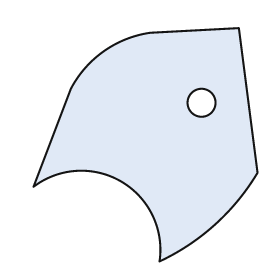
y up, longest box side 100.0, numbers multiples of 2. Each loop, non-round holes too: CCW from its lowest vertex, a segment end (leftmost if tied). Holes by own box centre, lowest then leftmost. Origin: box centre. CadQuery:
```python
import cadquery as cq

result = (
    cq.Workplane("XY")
    .moveTo(6.0, -50.0)
    .threePointArc((30.0, -34.0), (48.0, -12.0))
    .lineTo(40.0, 50.0)
    .lineTo(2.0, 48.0)
    .threePointArc((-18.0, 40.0), (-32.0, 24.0))
    .lineTo(-48.0, -18.0)
    .threePointArc((-10.0, -16.0), (6.0, -50.0))
    .close()
    .moveTo(24.0, 18.0)
    .circle(6.0)
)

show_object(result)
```